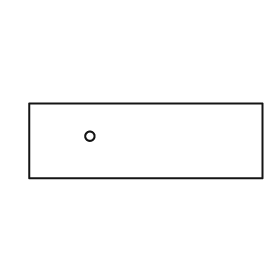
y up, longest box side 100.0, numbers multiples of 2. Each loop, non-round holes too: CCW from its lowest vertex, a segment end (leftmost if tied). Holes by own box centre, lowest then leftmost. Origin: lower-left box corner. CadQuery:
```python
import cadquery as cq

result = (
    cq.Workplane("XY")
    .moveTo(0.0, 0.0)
    .lineTo(100.0, 0.0)
    .lineTo(100.0, 32.0)
    .lineTo(0.0, 32.0)
    .close()
    .moveTo(26.0, 18.0)
    .circle(2.0)
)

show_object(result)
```